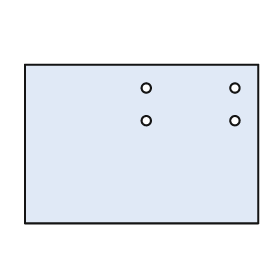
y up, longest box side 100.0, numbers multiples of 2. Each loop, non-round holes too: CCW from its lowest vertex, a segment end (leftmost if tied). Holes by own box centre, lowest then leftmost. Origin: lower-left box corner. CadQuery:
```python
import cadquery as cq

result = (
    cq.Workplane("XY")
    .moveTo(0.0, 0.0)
    .lineTo(100.0, 0.0)
    .lineTo(100.0, 68.0)
    .lineTo(0.0, 68.0)
    .close()
    .moveTo(52.0, 44.0)
    .circle(2.0)
    .moveTo(90.0, 44.0)
    .circle(2.0)
    .moveTo(52.0, 58.0)
    .circle(2.0)
    .moveTo(90.0, 58.0)
    .circle(2.0)
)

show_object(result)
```